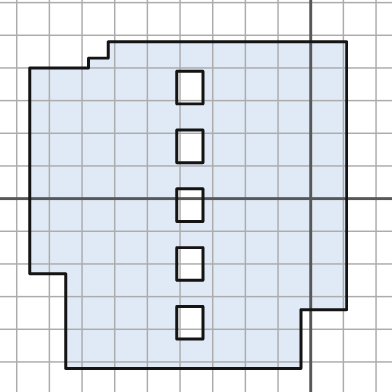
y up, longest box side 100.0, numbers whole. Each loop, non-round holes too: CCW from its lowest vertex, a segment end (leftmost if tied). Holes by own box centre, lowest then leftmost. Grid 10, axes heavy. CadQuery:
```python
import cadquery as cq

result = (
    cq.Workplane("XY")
    .moveTo(-75.0, -52.0)
    .lineTo(-3.0, -52.0)
    .lineTo(-3.0, -34.0)
    .lineTo(11.0, -34.0)
    .lineTo(11.0, 48.0)
    .lineTo(-62.0, 48.0)
    .lineTo(-62.0, 43.0)
    .lineTo(-68.0, 43.0)
    .lineTo(-68.0, 40.0)
    .lineTo(-86.0, 40.0)
    .lineTo(-86.0, -23.0)
    .lineTo(-75.0, -23.0)
    .close()
    .moveTo(-41.0, -43.0)
    .lineTo(-33.0, -43.0)
    .lineTo(-33.0, -33.0)
    .lineTo(-41.0, -33.0)
    .close()
    .moveTo(-41.0, -25.0)
    .lineTo(-33.0, -25.0)
    .lineTo(-33.0, -15.0)
    .lineTo(-41.0, -15.0)
    .close()
    .moveTo(-41.0, -7.0)
    .lineTo(-33.0, -7.0)
    .lineTo(-33.0, 3.0)
    .lineTo(-41.0, 3.0)
    .close()
    .moveTo(-41.0, 11.0)
    .lineTo(-33.0, 11.0)
    .lineTo(-33.0, 21.0)
    .lineTo(-41.0, 21.0)
    .close()
    .moveTo(-41.0, 29.0)
    .lineTo(-33.0, 29.0)
    .lineTo(-33.0, 39.0)
    .lineTo(-41.0, 39.0)
    .close()
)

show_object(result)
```